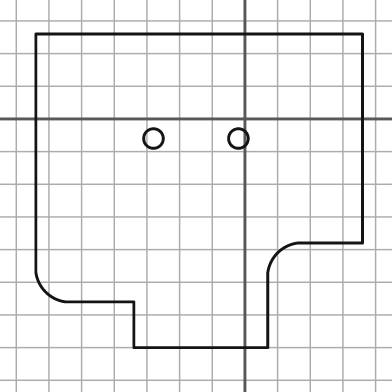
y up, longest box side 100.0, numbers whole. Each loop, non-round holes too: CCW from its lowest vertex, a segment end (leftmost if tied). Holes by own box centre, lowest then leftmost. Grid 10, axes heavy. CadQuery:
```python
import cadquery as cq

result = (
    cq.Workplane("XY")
    .moveTo(-34.0, -70.0)
    .lineTo(7.0, -70.0)
    .lineTo(7.0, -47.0)
    .threePointArc((10.0, -41.0), (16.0, -38.0))
    .lineTo(36.0, -38.0)
    .lineTo(36.0, 26.0)
    .lineTo(-64.0, 26.0)
    .lineTo(-64.0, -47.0)
    .threePointArc((-61.0, -53.0), (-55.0, -56.0))
    .lineTo(-34.0, -56.0)
    .close()
    .moveTo(-28.0, -6.0)
    .circle(3.0)
    .moveTo(-2.0, -6.0)
    .circle(3.0)
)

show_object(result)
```